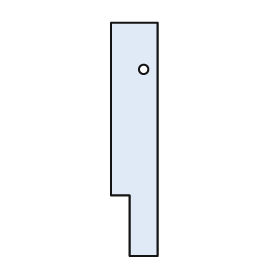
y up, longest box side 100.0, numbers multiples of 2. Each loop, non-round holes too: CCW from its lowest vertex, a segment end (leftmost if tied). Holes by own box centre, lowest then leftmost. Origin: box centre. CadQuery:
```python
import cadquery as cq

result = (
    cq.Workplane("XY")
    .moveTo(-2.0, -50.0)
    .lineTo(10.0, -50.0)
    .lineTo(10.0, 50.0)
    .lineTo(-10.0, 50.0)
    .lineTo(-10.0, -24.0)
    .lineTo(-2.0, -24.0)
    .close()
    .moveTo(4.0, 30.0)
    .circle(2.0)
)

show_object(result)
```